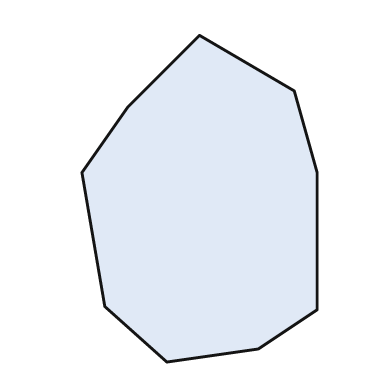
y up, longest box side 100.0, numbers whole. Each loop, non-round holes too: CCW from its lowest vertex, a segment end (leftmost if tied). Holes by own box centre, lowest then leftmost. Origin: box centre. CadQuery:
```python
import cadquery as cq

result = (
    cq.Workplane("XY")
    .moveTo(-10.0, -50.0)
    .lineTo(18.0, -46.0)
    .lineTo(36.0, -34.0)
    .lineTo(36.0, 8.0)
    .lineTo(29.0, 33.0)
    .lineTo(0.0, 50.0)
    .lineTo(-22.0, 28.0)
    .lineTo(-36.0, 8.0)
    .lineTo(-29.0, -33.0)
    .close()
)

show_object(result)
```